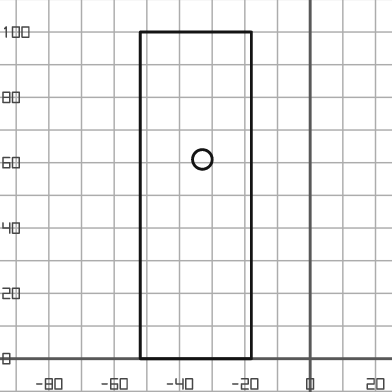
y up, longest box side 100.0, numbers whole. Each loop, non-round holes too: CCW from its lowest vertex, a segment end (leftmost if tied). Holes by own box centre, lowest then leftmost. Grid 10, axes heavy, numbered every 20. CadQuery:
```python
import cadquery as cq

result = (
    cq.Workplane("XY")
    .moveTo(-52.0, 0.0)
    .lineTo(-18.0, 0.0)
    .lineTo(-18.0, 100.0)
    .lineTo(-52.0, 100.0)
    .close()
    .moveTo(-33.0, 61.0)
    .circle(3.0)
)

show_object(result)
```